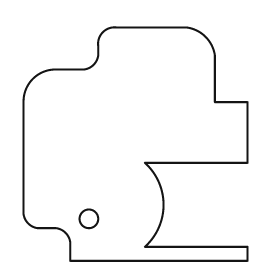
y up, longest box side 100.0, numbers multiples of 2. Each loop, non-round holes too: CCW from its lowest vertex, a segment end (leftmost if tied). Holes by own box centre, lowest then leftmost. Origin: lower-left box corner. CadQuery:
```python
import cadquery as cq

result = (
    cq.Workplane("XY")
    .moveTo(20.0, 0.0)
    .lineTo(96.0, 0.0)
    .lineTo(96.0, 6.0)
    .lineTo(52.0, 6.0)
    .threePointArc((60.0, 24.0), (52.0, 42.0))
    .lineTo(96.0, 42.0)
    .lineTo(96.0, 68.0)
    .lineTo(82.0, 68.0)
    .lineTo(82.0, 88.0)
    .threePointArc((78.0, 96.0), (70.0, 100.0))
    .lineTo(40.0, 100.0)
    .threePointArc((34.0, 98.0), (32.0, 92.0))
    .lineTo(32.0, 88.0)
    .threePointArc((30.0, 84.0), (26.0, 82.0))
    .lineTo(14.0, 82.0)
    .threePointArc((4.0, 78.0), (0.0, 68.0))
    .lineTo(0.0, 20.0)
    .threePointArc((2.0, 16.0), (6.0, 14.0))
    .lineTo(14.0, 14.0)
    .threePointArc((18.0, 12.0), (20.0, 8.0))
    .close()
    .moveTo(28.0, 18.0)
    .circle(4.0)
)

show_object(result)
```